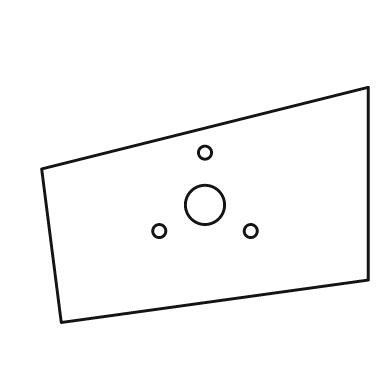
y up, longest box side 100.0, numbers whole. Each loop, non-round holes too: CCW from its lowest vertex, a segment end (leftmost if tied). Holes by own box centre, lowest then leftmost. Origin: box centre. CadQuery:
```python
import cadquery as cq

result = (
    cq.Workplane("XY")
    .moveTo(-44.0, -36.0)
    .lineTo(50.0, -23.0)
    .lineTo(50.0, 36.0)
    .lineTo(-50.0, 11.0)
    .close()
    .moveTo(-14.0, -8.0)
    .circle(2.0)
    .moveTo(14.0, -8.0)
    .circle(2.0)
    .moveTo(0.0, 0.0)
    .circle(6.0)
    .moveTo(0.0, 16.0)
    .circle(2.0)
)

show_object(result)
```